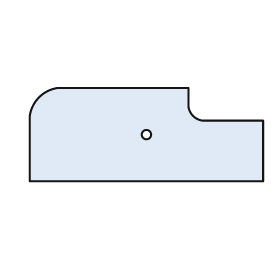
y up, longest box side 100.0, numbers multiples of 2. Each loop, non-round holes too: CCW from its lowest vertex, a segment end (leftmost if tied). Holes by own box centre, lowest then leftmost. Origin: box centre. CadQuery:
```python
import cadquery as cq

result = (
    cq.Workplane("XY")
    .moveTo(-50.0, -20.0)
    .lineTo(50.0, -20.0)
    .lineTo(50.0, 6.0)
    .lineTo(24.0, 6.0)
    .threePointArc((20.0, 8.0), (18.0, 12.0))
    .lineTo(18.0, 20.0)
    .lineTo(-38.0, 20.0)
    .threePointArc((-46.0, 16.0), (-50.0, 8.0))
    .close()
    .moveTo(0.0, 0.0)
    .circle(2.0)
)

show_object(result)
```